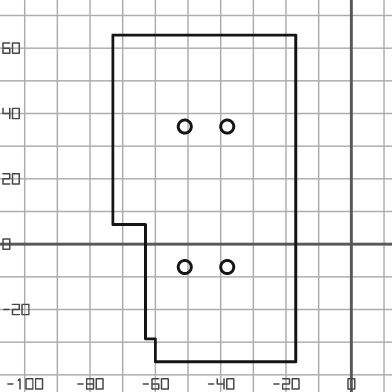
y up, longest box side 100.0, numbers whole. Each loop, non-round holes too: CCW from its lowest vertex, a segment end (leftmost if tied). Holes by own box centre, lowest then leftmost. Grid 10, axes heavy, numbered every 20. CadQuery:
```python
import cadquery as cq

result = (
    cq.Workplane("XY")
    .moveTo(-60.0, -36.0)
    .lineTo(-17.0, -36.0)
    .lineTo(-17.0, 64.0)
    .lineTo(-73.0, 64.0)
    .lineTo(-73.0, 6.0)
    .lineTo(-63.0, 6.0)
    .lineTo(-63.0, -29.0)
    .lineTo(-60.0, -29.0)
    .close()
    .moveTo(-51.0, -7.0)
    .circle(2.0)
    .moveTo(-38.0, -7.0)
    .circle(2.0)
    .moveTo(-51.0, 36.0)
    .circle(2.0)
    .moveTo(-38.0, 36.0)
    .circle(2.0)
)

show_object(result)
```